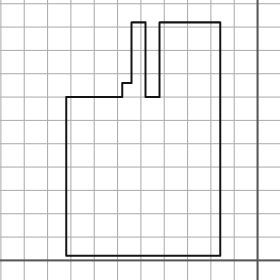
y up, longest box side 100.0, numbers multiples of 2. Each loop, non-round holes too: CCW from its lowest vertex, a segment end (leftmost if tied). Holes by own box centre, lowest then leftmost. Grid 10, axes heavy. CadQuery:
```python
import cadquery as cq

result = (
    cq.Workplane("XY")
    .moveTo(-82.0, 2.0)
    .lineTo(-16.0, 2.0)
    .lineTo(-16.0, 102.0)
    .lineTo(-42.0, 102.0)
    .lineTo(-42.0, 70.0)
    .lineTo(-48.0, 70.0)
    .lineTo(-48.0, 102.0)
    .lineTo(-54.0, 102.0)
    .lineTo(-54.0, 76.0)
    .lineTo(-58.0, 76.0)
    .lineTo(-58.0, 70.0)
    .lineTo(-82.0, 70.0)
    .close()
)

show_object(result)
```